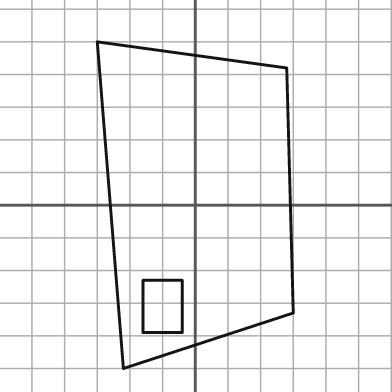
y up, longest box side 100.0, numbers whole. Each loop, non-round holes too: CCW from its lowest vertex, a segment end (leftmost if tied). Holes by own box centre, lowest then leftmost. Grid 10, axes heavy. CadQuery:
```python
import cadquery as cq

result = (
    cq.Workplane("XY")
    .moveTo(-22.0, -50.0)
    .lineTo(30.0, -33.0)
    .lineTo(28.0, 42.0)
    .lineTo(-30.0, 50.0)
    .close()
    .moveTo(-16.0, -39.0)
    .lineTo(-4.0, -39.0)
    .lineTo(-4.0, -23.0)
    .lineTo(-16.0, -23.0)
    .close()
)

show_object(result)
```